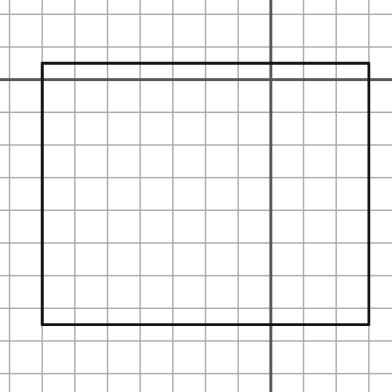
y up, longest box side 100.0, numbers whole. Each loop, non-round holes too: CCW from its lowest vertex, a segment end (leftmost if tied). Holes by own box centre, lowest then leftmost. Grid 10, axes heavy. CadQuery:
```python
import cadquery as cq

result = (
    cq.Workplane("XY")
    .moveTo(-70.0, -75.0)
    .lineTo(30.0, -75.0)
    .lineTo(30.0, 5.0)
    .lineTo(-70.0, 5.0)
    .close()
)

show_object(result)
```